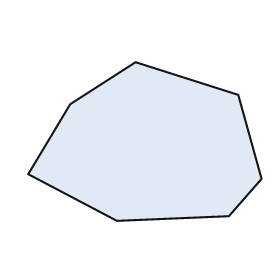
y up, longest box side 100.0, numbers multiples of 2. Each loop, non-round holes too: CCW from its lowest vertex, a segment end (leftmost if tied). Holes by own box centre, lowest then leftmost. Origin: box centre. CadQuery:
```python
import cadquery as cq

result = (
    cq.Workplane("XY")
    .moveTo(-12.0, -34.0)
    .lineTo(36.0, -32.0)
    .lineTo(50.0, -16.0)
    .lineTo(40.0, 20.0)
    .lineTo(-4.0, 34.0)
    .lineTo(-32.0, 16.0)
    .lineTo(-50.0, -14.0)
    .close()
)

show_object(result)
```